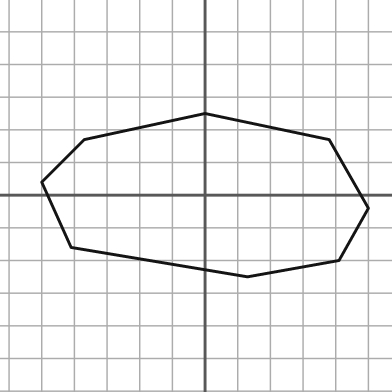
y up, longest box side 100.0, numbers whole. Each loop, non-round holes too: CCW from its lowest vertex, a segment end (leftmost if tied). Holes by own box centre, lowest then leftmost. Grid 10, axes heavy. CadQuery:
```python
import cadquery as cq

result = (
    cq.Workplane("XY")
    .moveTo(13.0, -25.0)
    .lineTo(41.0, -20.0)
    .lineTo(50.0, -4.0)
    .lineTo(38.0, 17.0)
    .lineTo(0.0, 25.0)
    .lineTo(-37.0, 17.0)
    .lineTo(-50.0, 4.0)
    .lineTo(-41.0, -16.0)
    .close()
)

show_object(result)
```